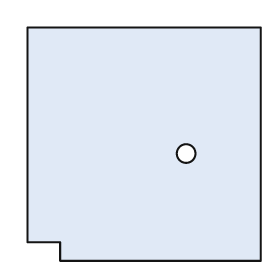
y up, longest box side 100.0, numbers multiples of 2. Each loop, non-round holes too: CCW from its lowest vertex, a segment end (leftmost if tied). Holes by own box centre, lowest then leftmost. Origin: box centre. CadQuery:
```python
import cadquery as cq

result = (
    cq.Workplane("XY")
    .moveTo(-36.0, -50.0)
    .lineTo(50.0, -50.0)
    .lineTo(50.0, 50.0)
    .lineTo(-50.0, 50.0)
    .lineTo(-50.0, -42.0)
    .lineTo(-36.0, -42.0)
    .close()
    .moveTo(18.0, -4.0)
    .circle(4.0)
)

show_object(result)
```